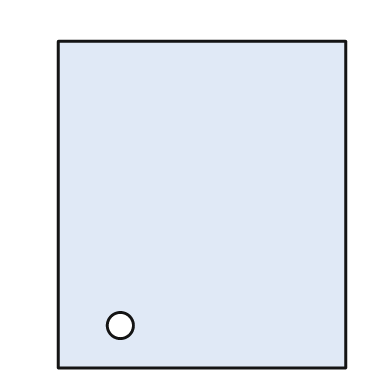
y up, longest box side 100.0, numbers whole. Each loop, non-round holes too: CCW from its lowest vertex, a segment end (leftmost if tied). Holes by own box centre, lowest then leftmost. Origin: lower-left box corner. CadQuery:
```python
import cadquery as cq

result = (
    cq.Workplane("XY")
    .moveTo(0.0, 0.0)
    .lineTo(88.0, 0.0)
    .lineTo(88.0, 100.0)
    .lineTo(0.0, 100.0)
    .close()
    .moveTo(19.0, 13.0)
    .circle(4.0)
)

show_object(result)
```